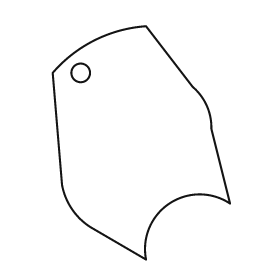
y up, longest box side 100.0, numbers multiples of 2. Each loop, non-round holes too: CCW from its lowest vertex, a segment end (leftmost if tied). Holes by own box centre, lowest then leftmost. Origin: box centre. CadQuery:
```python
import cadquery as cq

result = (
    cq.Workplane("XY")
    .moveTo(2.0, -50.0)
    .threePointArc((12.0, -26.0), (38.0, -26.0))
    .lineTo(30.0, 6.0)
    .threePointArc((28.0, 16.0), (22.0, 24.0))
    .lineTo(2.0, 50.0)
    .threePointArc((-20.0, 44.0), (-38.0, 30.0))
    .lineTo(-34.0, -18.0)
    .threePointArc((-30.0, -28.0), (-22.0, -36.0))
    .close()
    .moveTo(-26.0, 30.0)
    .circle(4.0)
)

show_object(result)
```